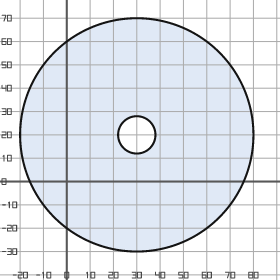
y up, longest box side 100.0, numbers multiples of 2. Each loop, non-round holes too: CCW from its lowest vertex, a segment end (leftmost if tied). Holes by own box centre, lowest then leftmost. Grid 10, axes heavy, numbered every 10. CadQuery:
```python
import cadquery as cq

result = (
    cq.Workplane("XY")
    .moveTo(30.0, 20.0)
    .circle(50.0)
    .moveTo(30.0, 20.0)
    .circle(8.0)
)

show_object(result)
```